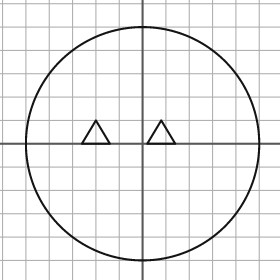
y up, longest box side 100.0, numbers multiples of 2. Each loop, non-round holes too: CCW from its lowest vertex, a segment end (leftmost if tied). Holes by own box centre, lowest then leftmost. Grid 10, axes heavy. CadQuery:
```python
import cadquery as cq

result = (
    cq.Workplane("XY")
    .moveTo(0.0, 0.0)
    .circle(50.0)
    .moveTo(-26.0, 0.0)
    .lineTo(-14.0, 0.0)
    .lineTo(-20.0, 10.0)
    .close()
    .moveTo(2.0, 0.0)
    .lineTo(14.0, 0.0)
    .lineTo(8.0, 10.0)
    .close()
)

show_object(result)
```